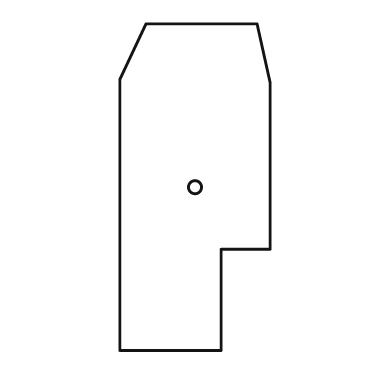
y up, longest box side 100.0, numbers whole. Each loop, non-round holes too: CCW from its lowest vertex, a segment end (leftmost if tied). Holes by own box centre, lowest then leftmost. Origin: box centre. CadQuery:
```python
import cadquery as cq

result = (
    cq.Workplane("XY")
    .moveTo(-23.0, -50.0)
    .lineTo(8.0, -50.0)
    .lineTo(8.0, -19.0)
    .lineTo(23.0, -19.0)
    .lineTo(23.0, 32.0)
    .lineTo(19.0, 50.0)
    .lineTo(-15.0, 50.0)
    .lineTo(-23.0, 33.0)
    .close()
    .moveTo(0.0, 0.0)
    .circle(2.0)
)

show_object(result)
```